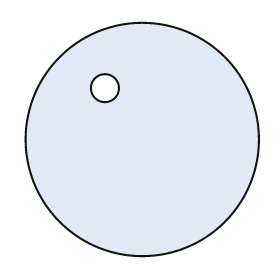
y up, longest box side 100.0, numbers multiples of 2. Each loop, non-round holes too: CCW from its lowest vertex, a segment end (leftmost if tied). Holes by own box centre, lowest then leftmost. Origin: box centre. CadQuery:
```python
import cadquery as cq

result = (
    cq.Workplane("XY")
    .moveTo(0.0, 0.0)
    .circle(50.0)
    .moveTo(-16.0, 22.0)
    .circle(6.0)
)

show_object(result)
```